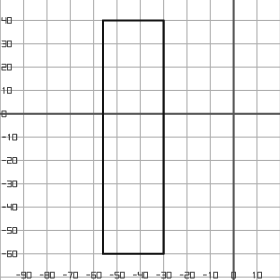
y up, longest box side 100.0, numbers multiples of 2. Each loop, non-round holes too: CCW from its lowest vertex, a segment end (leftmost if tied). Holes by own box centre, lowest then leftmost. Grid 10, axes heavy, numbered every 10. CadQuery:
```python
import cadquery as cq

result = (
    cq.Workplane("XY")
    .moveTo(-56.0, -60.0)
    .lineTo(-30.0, -60.0)
    .lineTo(-30.0, 40.0)
    .lineTo(-56.0, 40.0)
    .close()
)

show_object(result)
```